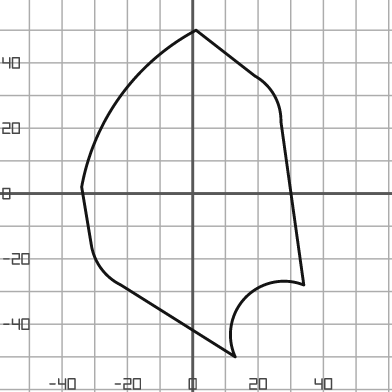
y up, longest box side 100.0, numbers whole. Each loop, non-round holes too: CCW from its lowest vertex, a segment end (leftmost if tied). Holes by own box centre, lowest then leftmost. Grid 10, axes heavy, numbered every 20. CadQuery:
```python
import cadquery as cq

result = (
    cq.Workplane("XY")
    .moveTo(13.0, -50.0)
    .threePointArc((16.0, -32.0), (34.0, -28.0))
    .lineTo(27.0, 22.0)
    .threePointArc((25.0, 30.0), (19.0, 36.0))
    .lineTo(1.0, 50.0)
    .threePointArc((-22.0, 30.0), (-34.0, 2.0))
    .lineTo(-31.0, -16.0)
    .threePointArc((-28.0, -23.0), (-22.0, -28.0))
    .close()
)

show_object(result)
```